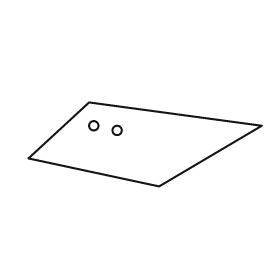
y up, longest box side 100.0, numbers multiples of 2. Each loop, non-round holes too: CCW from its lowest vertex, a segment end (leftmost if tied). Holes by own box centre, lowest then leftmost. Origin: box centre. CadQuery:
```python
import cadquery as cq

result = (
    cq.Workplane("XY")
    .moveTo(6.0, -18.0)
    .lineTo(50.0, 8.0)
    .lineTo(-24.0, 18.0)
    .lineTo(-50.0, -6.0)
    .close()
    .moveTo(-12.0, 6.0)
    .circle(2.0)
    .moveTo(-22.0, 8.0)
    .circle(2.0)
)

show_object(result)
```